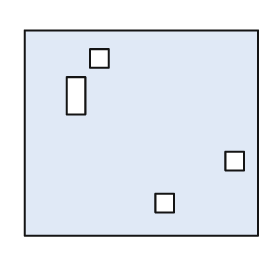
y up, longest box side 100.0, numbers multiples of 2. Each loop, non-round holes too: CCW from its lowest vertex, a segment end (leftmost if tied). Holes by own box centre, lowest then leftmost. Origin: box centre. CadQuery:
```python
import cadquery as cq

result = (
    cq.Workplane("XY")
    .moveTo(-50.0, -44.0)
    .lineTo(50.0, -44.0)
    .lineTo(50.0, 44.0)
    .lineTo(-50.0, 44.0)
    .close()
    .moveTo(6.0, -34.0)
    .lineTo(14.0, -34.0)
    .lineTo(14.0, -26.0)
    .lineTo(6.0, -26.0)
    .close()
    .moveTo(36.0, -16.0)
    .lineTo(44.0, -16.0)
    .lineTo(44.0, -8.0)
    .lineTo(36.0, -8.0)
    .close()
    .moveTo(-32.0, 8.0)
    .lineTo(-24.0, 8.0)
    .lineTo(-24.0, 24.0)
    .lineTo(-32.0, 24.0)
    .close()
    .moveTo(-22.0, 28.0)
    .lineTo(-14.0, 28.0)
    .lineTo(-14.0, 36.0)
    .lineTo(-22.0, 36.0)
    .close()
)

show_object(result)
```